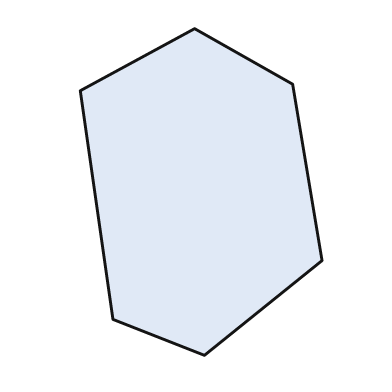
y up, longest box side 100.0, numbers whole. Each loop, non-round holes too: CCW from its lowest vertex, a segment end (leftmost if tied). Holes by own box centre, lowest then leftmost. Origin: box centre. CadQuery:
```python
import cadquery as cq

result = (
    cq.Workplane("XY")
    .moveTo(1.0, -50.0)
    .lineTo(37.0, -21.0)
    .lineTo(28.0, 33.0)
    .lineTo(-2.0, 50.0)
    .lineTo(-37.0, 31.0)
    .lineTo(-27.0, -39.0)
    .close()
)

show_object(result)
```